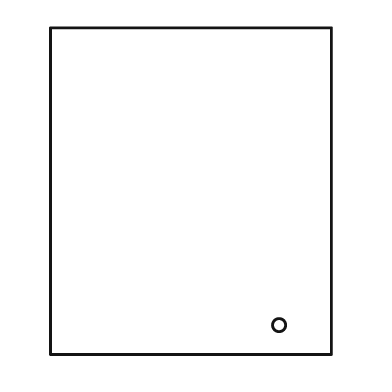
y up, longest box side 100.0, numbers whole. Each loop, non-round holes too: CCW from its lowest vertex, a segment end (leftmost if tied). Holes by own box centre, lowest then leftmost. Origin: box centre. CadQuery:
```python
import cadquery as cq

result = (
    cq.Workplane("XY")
    .moveTo(-43.0, -50.0)
    .lineTo(43.0, -50.0)
    .lineTo(43.0, 50.0)
    .lineTo(-43.0, 50.0)
    .close()
    .moveTo(27.0, -41.0)
    .circle(2.0)
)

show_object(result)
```